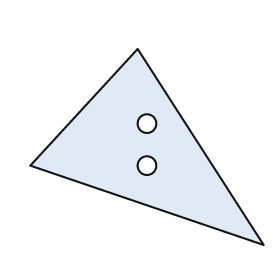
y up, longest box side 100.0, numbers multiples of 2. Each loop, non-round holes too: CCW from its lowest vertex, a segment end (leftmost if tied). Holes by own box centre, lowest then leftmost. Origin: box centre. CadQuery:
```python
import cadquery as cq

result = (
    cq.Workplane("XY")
    .moveTo(50.0, -42.0)
    .lineTo(-4.0, 42.0)
    .lineTo(-50.0, -8.0)
    .close()
    .moveTo(0.0, -8.0)
    .circle(4.0)
    .moveTo(0.0, 10.0)
    .circle(4.0)
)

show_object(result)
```